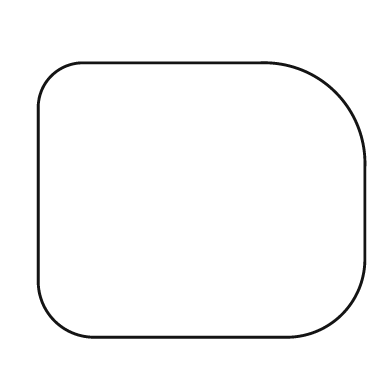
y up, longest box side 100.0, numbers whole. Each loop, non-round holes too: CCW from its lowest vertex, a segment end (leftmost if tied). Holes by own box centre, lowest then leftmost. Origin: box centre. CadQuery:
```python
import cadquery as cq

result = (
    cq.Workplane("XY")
    .moveTo(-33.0, -42.0)
    .lineTo(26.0, -42.0)
    .threePointArc((43.0, -35.0), (50.0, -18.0))
    .lineTo(50.0, 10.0)
    .threePointArc((41.0, 33.0), (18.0, 42.0))
    .lineTo(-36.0, 42.0)
    .threePointArc((-46.0, 38.0), (-50.0, 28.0))
    .lineTo(-50.0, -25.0)
    .threePointArc((-45.0, -37.0), (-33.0, -42.0))
    .close()
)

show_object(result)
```